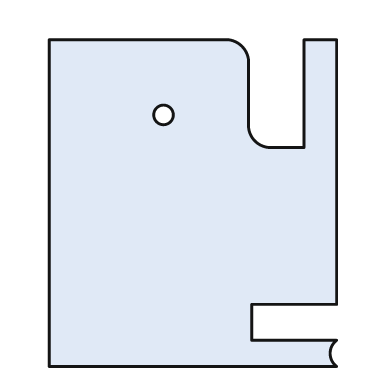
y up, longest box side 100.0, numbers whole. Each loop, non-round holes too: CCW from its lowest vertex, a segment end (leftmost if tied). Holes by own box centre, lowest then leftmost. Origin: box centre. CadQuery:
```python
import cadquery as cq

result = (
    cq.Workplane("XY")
    .moveTo(-44.0, -50.0)
    .lineTo(44.0, -50.0)
    .threePointArc((42.0, -46.0), (44.0, -42.0))
    .lineTo(18.0, -42.0)
    .lineTo(18.0, -31.0)
    .lineTo(44.0, -31.0)
    .lineTo(44.0, 50.0)
    .lineTo(34.0, 50.0)
    .lineTo(34.0, 17.0)
    .lineTo(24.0, 17.0)
    .threePointArc((19.0, 19.0), (17.0, 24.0))
    .lineTo(17.0, 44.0)
    .threePointArc((15.0, 48.0), (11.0, 50.0))
    .lineTo(-44.0, 50.0)
    .close()
    .moveTo(-9.0, 27.0)
    .circle(3.0)
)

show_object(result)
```